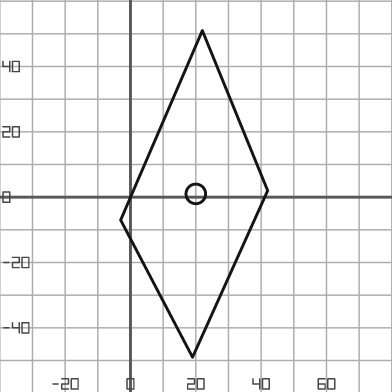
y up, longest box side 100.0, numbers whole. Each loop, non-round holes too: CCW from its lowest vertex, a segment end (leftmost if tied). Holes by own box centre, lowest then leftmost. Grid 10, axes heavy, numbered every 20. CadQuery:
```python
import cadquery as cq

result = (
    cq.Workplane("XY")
    .moveTo(19.0, -49.0)
    .lineTo(42.0, 2.0)
    .lineTo(22.0, 51.0)
    .lineTo(-3.0, -7.0)
    .close()
    .moveTo(20.0, 1.0)
    .circle(3.0)
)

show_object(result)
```